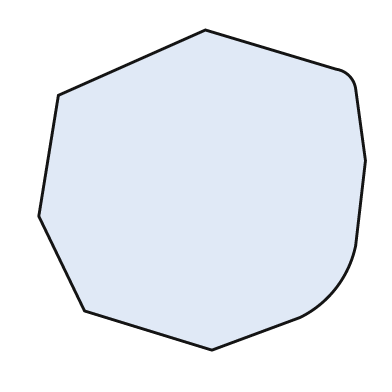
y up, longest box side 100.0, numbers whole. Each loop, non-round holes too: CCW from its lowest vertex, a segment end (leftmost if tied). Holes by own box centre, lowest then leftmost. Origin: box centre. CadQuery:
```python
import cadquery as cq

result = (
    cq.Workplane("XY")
    .moveTo(3.0, -49.0)
    .lineTo(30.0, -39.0)
    .threePointArc((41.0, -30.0), (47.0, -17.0))
    .lineTo(50.0, 9.0)
    .lineTo(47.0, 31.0)
    .threePointArc((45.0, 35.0), (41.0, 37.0))
    .lineTo(1.0, 49.0)
    .lineTo(-44.0, 29.0)
    .lineTo(-50.0, -8.0)
    .lineTo(-36.0, -37.0)
    .close()
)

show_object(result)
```